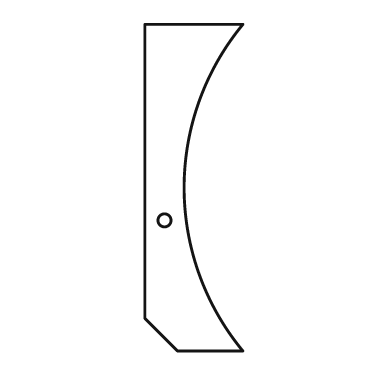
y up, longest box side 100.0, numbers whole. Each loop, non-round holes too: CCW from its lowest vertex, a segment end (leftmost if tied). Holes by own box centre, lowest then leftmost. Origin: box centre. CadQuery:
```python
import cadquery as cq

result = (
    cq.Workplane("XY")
    .moveTo(-5.0, -50.0)
    .lineTo(15.0, -50.0)
    .threePointArc((-3.0, 0.0), (15.0, 50.0))
    .lineTo(-15.0, 50.0)
    .lineTo(-15.0, -40.0)
    .close()
    .moveTo(-9.0, -10.0)
    .circle(2.0)
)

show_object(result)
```